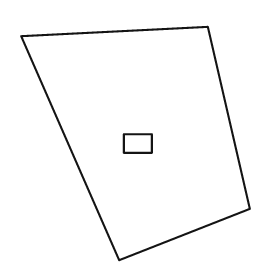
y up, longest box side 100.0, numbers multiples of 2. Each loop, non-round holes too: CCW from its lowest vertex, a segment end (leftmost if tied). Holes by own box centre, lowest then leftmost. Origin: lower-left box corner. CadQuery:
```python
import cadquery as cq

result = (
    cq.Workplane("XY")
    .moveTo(42.0, 0.0)
    .lineTo(98.0, 22.0)
    .lineTo(80.0, 100.0)
    .lineTo(0.0, 96.0)
    .close()
    .moveTo(44.0, 46.0)
    .lineTo(56.0, 46.0)
    .lineTo(56.0, 54.0)
    .lineTo(44.0, 54.0)
    .close()
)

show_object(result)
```